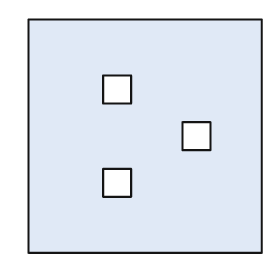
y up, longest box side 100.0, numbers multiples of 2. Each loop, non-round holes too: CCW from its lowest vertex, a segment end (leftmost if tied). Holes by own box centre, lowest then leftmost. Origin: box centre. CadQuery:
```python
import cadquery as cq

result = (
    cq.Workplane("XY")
    .moveTo(-50.0, -50.0)
    .lineTo(50.0, -50.0)
    .lineTo(50.0, 50.0)
    .lineTo(-50.0, 50.0)
    .close()
    .moveTo(-18.0, -26.0)
    .lineTo(-6.0, -26.0)
    .lineTo(-6.0, -14.0)
    .lineTo(-18.0, -14.0)
    .close()
    .moveTo(16.0, -6.0)
    .lineTo(28.0, -6.0)
    .lineTo(28.0, 6.0)
    .lineTo(16.0, 6.0)
    .close()
    .moveTo(-18.0, 14.0)
    .lineTo(-6.0, 14.0)
    .lineTo(-6.0, 26.0)
    .lineTo(-18.0, 26.0)
    .close()
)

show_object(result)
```